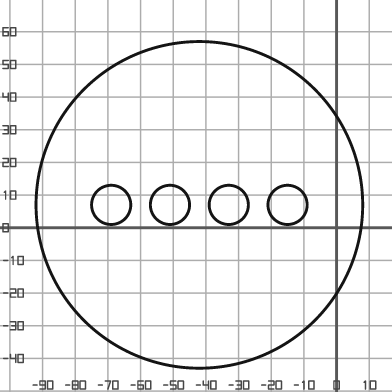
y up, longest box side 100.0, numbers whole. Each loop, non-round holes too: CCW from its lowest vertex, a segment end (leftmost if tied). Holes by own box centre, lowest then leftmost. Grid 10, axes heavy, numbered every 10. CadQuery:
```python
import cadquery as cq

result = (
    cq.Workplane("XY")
    .moveTo(-42.0, 7.0)
    .circle(50.0)
    .moveTo(-69.0, 7.0)
    .circle(6.0)
    .moveTo(-51.0, 7.0)
    .circle(6.0)
    .moveTo(-33.0, 7.0)
    .circle(6.0)
    .moveTo(-15.0, 7.0)
    .circle(6.0)
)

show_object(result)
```